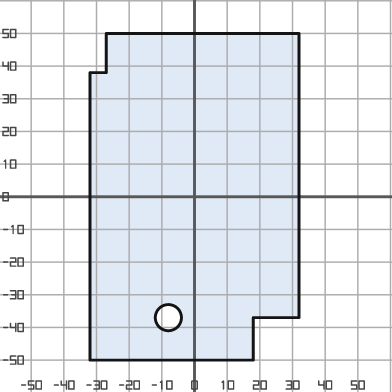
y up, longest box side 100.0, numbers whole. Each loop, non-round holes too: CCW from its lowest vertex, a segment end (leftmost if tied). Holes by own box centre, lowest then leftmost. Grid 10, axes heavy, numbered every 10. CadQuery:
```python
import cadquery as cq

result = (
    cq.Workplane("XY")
    .moveTo(-32.0, -50.0)
    .lineTo(18.0, -50.0)
    .lineTo(18.0, -37.0)
    .lineTo(32.0, -37.0)
    .lineTo(32.0, 50.0)
    .lineTo(-27.0, 50.0)
    .lineTo(-27.0, 38.0)
    .lineTo(-32.0, 38.0)
    .close()
    .moveTo(-8.0, -37.0)
    .circle(4.0)
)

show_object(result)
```